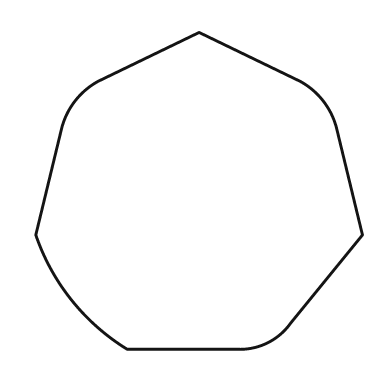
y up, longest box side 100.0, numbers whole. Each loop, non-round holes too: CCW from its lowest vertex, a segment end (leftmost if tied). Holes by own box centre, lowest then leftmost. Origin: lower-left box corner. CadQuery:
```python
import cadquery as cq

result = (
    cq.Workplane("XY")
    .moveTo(28.0, 0.0)
    .lineTo(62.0, 0.0)
    .threePointArc((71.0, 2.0), (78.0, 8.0))
    .lineTo(100.0, 35.0)
    .lineTo(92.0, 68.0)
    .threePointArc((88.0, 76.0), (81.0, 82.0))
    .lineTo(50.0, 97.0)
    .lineTo(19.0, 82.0)
    .threePointArc((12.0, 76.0), (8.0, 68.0))
    .lineTo(0.0, 35.0)
    .threePointArc((11.0, 15.0), (28.0, 0.0))
    .close()
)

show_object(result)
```